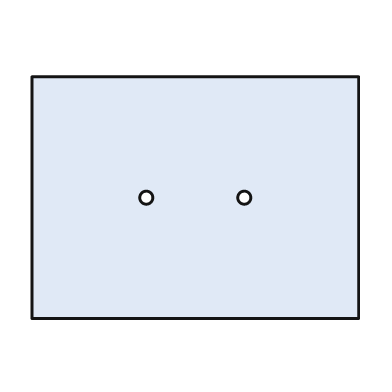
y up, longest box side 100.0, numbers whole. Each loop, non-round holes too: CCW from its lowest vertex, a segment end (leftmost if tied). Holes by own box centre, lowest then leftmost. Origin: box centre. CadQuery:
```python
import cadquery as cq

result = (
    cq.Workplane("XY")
    .moveTo(-50.0, -37.0)
    .lineTo(50.0, -37.0)
    .lineTo(50.0, 37.0)
    .lineTo(-50.0, 37.0)
    .close()
    .moveTo(-15.0, 0.0)
    .circle(2.0)
    .moveTo(15.0, 0.0)
    .circle(2.0)
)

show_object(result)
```